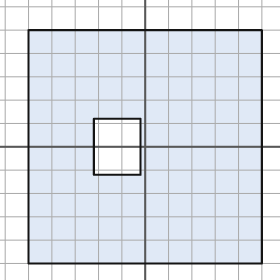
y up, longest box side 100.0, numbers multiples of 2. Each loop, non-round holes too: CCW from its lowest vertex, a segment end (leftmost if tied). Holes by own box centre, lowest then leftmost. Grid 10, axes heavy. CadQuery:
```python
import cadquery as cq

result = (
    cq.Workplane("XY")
    .moveTo(-50.0, -50.0)
    .lineTo(50.0, -50.0)
    .lineTo(50.0, 50.0)
    .lineTo(-50.0, 50.0)
    .close()
    .moveTo(-22.0, -12.0)
    .lineTo(-2.0, -12.0)
    .lineTo(-2.0, 12.0)
    .lineTo(-22.0, 12.0)
    .close()
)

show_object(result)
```